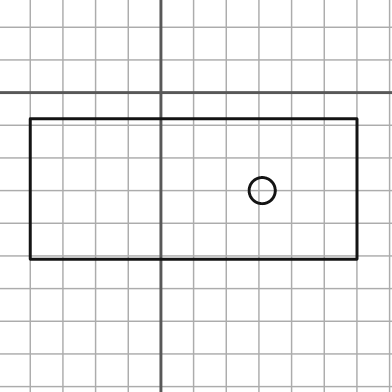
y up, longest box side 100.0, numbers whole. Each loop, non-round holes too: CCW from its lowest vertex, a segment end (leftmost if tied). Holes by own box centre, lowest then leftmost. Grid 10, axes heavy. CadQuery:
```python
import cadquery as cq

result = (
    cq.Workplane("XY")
    .moveTo(-40.0, -51.0)
    .lineTo(60.0, -51.0)
    .lineTo(60.0, -8.0)
    .lineTo(-40.0, -8.0)
    .close()
    .moveTo(31.0, -30.0)
    .circle(4.0)
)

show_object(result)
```